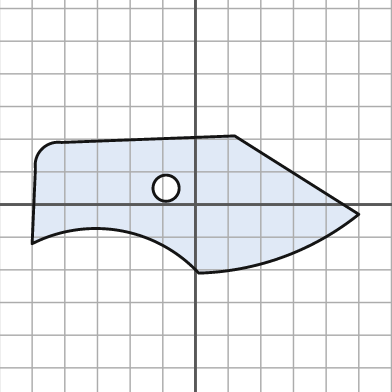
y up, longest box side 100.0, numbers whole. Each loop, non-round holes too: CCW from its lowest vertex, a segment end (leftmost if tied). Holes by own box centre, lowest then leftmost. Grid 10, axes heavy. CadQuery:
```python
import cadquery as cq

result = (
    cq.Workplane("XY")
    .moveTo(1.0, -21.0)
    .threePointArc((27.0, -16.0), (50.0, -3.0))
    .lineTo(12.0, 21.0)
    .lineTo(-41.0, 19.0)
    .threePointArc((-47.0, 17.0), (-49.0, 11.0))
    .lineTo(-50.0, -12.0)
    .threePointArc((-23.0, -8.0), (1.0, -21.0))
    .close()
    .moveTo(-9.0, 5.0)
    .circle(4.0)
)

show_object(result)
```